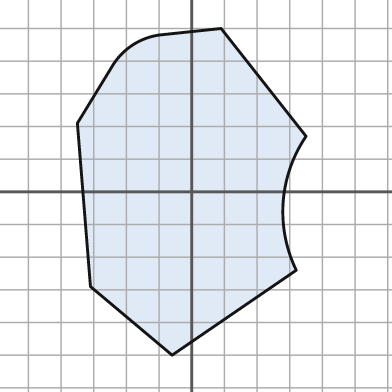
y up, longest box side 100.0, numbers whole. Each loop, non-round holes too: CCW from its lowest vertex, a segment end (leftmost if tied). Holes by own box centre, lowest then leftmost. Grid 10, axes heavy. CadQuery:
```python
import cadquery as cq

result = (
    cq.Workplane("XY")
    .moveTo(-6.0, -50.0)
    .lineTo(32.0, -24.0)
    .threePointArc((28.0, -3.0), (35.0, 17.0))
    .lineTo(9.0, 50.0)
    .lineTo(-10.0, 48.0)
    .threePointArc((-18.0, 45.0), (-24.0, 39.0))
    .lineTo(-35.0, 21.0)
    .lineTo(-31.0, -29.0)
    .close()
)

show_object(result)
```